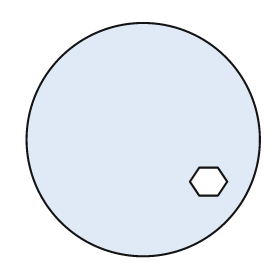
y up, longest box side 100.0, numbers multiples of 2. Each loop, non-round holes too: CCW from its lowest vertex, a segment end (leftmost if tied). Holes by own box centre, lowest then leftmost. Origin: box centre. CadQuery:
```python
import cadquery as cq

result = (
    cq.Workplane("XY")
    .moveTo(0.0, 0.0)
    .circle(50.0)
    .moveTo(24.0, -24.0)
    .lineTo(32.0, -24.0)
    .lineTo(36.0, -18.0)
    .lineTo(32.0, -12.0)
    .lineTo(24.0, -12.0)
    .lineTo(20.0, -18.0)
    .close()
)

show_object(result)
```